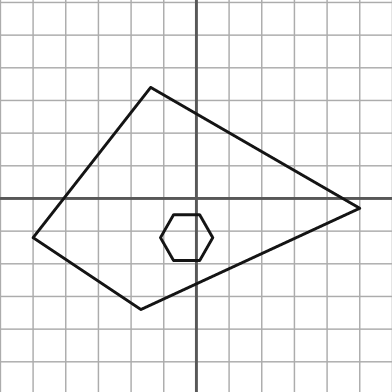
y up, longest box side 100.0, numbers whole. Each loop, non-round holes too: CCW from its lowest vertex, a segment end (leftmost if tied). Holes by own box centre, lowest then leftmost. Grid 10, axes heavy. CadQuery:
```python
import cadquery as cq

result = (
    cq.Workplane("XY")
    .moveTo(-17.0, -34.0)
    .lineTo(50.0, -3.0)
    .lineTo(-14.0, 34.0)
    .lineTo(-50.0, -12.0)
    .close()
    .moveTo(-7.0, -19.0)
    .lineTo(1.0, -19.0)
    .lineTo(5.0, -12.0)
    .lineTo(1.0, -5.0)
    .lineTo(-7.0, -5.0)
    .lineTo(-11.0, -12.0)
    .close()
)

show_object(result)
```